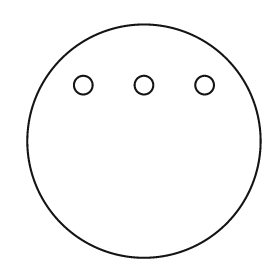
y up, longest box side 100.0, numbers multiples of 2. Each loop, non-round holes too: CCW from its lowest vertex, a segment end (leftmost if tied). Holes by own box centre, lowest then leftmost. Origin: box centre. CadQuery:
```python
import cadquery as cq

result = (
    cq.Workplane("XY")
    .moveTo(0.0, 0.0)
    .circle(50.0)
    .moveTo(-26.0, 24.0)
    .circle(4.0)
    .moveTo(0.0, 24.0)
    .circle(4.0)
    .moveTo(26.0, 24.0)
    .circle(4.0)
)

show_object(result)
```